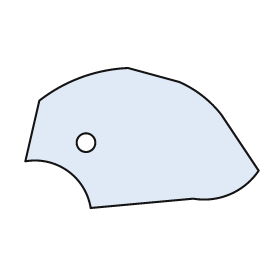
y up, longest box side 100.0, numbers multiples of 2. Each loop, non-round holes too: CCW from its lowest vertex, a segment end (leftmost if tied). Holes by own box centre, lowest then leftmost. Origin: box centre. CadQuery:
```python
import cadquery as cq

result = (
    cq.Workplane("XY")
    .moveTo(-22.0, -30.0)
    .lineTo(22.0, -26.0)
    .threePointArc((38.0, -24.0), (50.0, -14.0))
    .lineTo(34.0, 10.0)
    .threePointArc((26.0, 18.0), (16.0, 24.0))
    .lineTo(-6.0, 30.0)
    .threePointArc((-26.0, 26.0), (-44.0, 16.0))
    .lineTo(-50.0, -10.0)
    .threePointArc((-32.0, -14.0), (-22.0, -30.0))
    .close()
    .moveTo(-24.0, -2.0)
    .circle(4.0)
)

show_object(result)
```